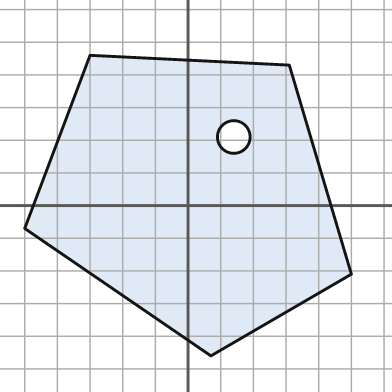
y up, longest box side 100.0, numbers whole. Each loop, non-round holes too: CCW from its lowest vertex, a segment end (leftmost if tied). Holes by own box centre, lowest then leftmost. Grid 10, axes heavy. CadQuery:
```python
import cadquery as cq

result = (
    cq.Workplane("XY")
    .moveTo(7.0, -46.0)
    .lineTo(50.0, -21.0)
    .lineTo(31.0, 43.0)
    .lineTo(-30.0, 46.0)
    .lineTo(-50.0, -7.0)
    .close()
    .moveTo(14.0, 21.0)
    .circle(5.0)
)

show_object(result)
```